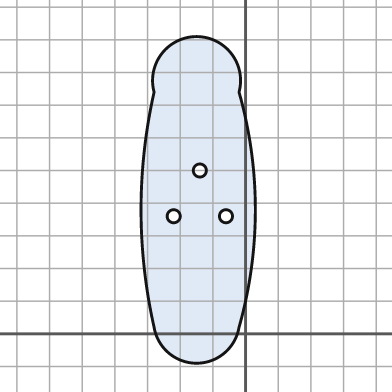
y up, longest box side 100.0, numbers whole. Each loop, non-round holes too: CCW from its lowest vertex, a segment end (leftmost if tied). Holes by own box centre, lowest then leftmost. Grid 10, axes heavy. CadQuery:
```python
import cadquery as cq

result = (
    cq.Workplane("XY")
    .moveTo(-28.0, 2.0)
    .threePointArc((-15.0, -9.0), (-2.0, 2.0))
    .threePointArc((3.0, 38.0), (-2.0, 74.0))
    .threePointArc((-15.0, 91.0), (-28.0, 74.0))
    .threePointArc((-32.0, 38.0), (-28.0, 2.0))
    .close()
    .moveTo(-22.0, 36.0)
    .circle(2.0)
    .moveTo(-6.0, 36.0)
    .circle(2.0)
    .moveTo(-14.0, 50.0)
    .circle(2.0)
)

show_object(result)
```